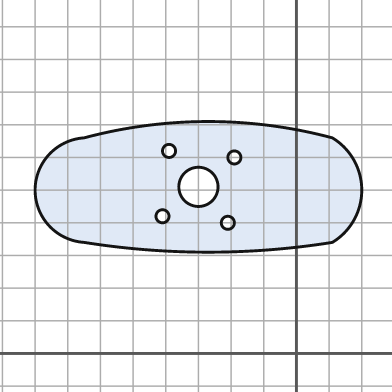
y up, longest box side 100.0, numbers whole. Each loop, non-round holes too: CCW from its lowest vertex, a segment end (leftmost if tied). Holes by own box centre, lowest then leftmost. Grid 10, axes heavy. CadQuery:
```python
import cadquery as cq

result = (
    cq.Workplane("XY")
    .moveTo(-65.0, 34.0)
    .threePointArc((-27.0, 31.0), (11.0, 34.0))
    .threePointArc((20.0, 50.0), (11.0, 66.0))
    .threePointArc((-27.0, 71.0), (-65.0, 66.0))
    .threePointArc((-80.0, 50.0), (-65.0, 34.0))
    .close()
    .moveTo(-21.0, 40.0)
    .circle(2.0)
    .moveTo(-41.0, 42.0)
    .circle(2.0)
    .moveTo(-30.0, 51.0)
    .circle(6.0)
    .moveTo(-19.0, 60.0)
    .circle(2.0)
    .moveTo(-39.0, 62.0)
    .circle(2.0)
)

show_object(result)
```